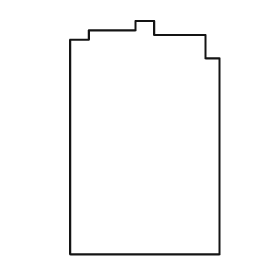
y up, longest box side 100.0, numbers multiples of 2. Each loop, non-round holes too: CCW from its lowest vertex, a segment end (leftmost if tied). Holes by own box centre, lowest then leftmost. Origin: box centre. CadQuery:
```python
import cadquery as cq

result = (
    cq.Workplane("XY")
    .moveTo(-32.0, -50.0)
    .lineTo(32.0, -50.0)
    .lineTo(32.0, 34.0)
    .lineTo(26.0, 34.0)
    .lineTo(26.0, 44.0)
    .lineTo(4.0, 44.0)
    .lineTo(4.0, 50.0)
    .lineTo(-4.0, 50.0)
    .lineTo(-4.0, 46.0)
    .lineTo(-24.0, 46.0)
    .lineTo(-24.0, 42.0)
    .lineTo(-32.0, 42.0)
    .close()
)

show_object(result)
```